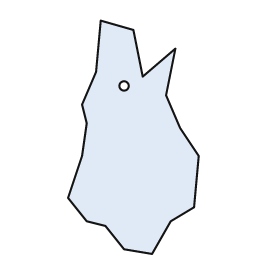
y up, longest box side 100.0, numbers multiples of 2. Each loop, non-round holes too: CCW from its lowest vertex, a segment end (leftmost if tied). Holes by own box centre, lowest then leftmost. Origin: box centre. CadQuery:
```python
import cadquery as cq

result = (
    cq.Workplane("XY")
    .moveTo(8.0, -50.0)
    .lineTo(16.0, -36.0)
    .lineTo(26.0, -30.0)
    .lineTo(28.0, -8.0)
    .lineTo(20.0, 4.0)
    .lineTo(14.0, 18.0)
    .lineTo(18.0, 38.0)
    .lineTo(4.0, 26.0)
    .lineTo(0.0, 46.0)
    .lineTo(-14.0, 50.0)
    .lineTo(-16.0, 28.0)
    .lineTo(-22.0, 14.0)
    .lineTo(-20.0, 6.0)
    .lineTo(-22.0, -8.0)
    .lineTo(-28.0, -26.0)
    .lineTo(-20.0, -36.0)
    .lineTo(-12.0, -38.0)
    .lineTo(-4.0, -48.0)
    .close()
    .moveTo(-4.0, 22.0)
    .circle(2.0)
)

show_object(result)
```